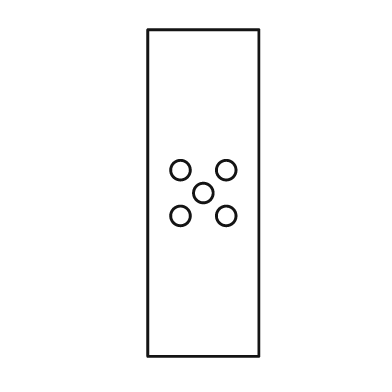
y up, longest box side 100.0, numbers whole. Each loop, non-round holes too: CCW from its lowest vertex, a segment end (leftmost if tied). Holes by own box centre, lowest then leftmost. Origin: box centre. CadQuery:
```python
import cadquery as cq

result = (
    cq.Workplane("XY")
    .moveTo(-17.0, -50.0)
    .lineTo(17.0, -50.0)
    .lineTo(17.0, 50.0)
    .lineTo(-17.0, 50.0)
    .close()
    .moveTo(-7.0, -7.0)
    .circle(3.0)
    .moveTo(7.0, -7.0)
    .circle(3.0)
    .moveTo(0.0, 0.0)
    .circle(3.0)
    .moveTo(-7.0, 7.0)
    .circle(3.0)
    .moveTo(7.0, 7.0)
    .circle(3.0)
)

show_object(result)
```